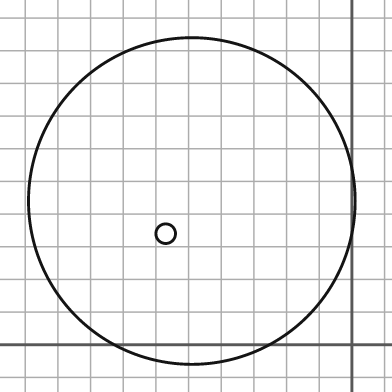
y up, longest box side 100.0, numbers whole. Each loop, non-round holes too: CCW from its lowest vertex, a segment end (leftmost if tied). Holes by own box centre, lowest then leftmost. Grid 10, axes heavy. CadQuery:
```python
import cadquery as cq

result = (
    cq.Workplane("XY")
    .moveTo(-49.0, 44.0)
    .circle(50.0)
    .moveTo(-57.0, 34.0)
    .circle(3.0)
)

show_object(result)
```